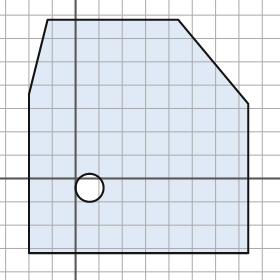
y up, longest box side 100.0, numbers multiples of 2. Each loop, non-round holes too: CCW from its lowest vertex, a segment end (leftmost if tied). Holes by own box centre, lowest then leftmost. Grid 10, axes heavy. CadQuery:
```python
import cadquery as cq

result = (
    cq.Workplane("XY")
    .moveTo(-20.0, -32.0)
    .lineTo(74.0, -32.0)
    .lineTo(74.0, 32.0)
    .lineTo(44.0, 68.0)
    .lineTo(-12.0, 68.0)
    .lineTo(-20.0, 36.0)
    .close()
    .moveTo(6.0, -4.0)
    .circle(6.0)
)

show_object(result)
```